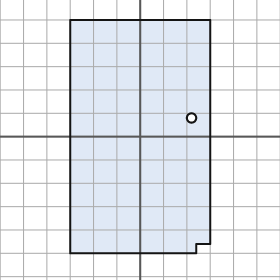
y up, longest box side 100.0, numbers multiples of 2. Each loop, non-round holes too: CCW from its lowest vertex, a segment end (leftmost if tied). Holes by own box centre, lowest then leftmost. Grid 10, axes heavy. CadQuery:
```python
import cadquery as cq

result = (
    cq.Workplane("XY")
    .moveTo(-30.0, -50.0)
    .lineTo(24.0, -50.0)
    .lineTo(24.0, -46.0)
    .lineTo(30.0, -46.0)
    .lineTo(30.0, 50.0)
    .lineTo(-30.0, 50.0)
    .close()
    .moveTo(22.0, 8.0)
    .circle(2.0)
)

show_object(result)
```